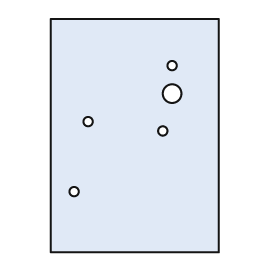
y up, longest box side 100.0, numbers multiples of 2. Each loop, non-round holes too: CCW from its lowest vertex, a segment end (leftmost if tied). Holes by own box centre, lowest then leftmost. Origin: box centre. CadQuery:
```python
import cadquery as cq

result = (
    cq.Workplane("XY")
    .moveTo(-36.0, -50.0)
    .lineTo(36.0, -50.0)
    .lineTo(36.0, 50.0)
    .lineTo(-36.0, 50.0)
    .close()
    .moveTo(-26.0, -24.0)
    .circle(2.0)
    .moveTo(12.0, 2.0)
    .circle(2.0)
    .moveTo(-20.0, 6.0)
    .circle(2.0)
    .moveTo(16.0, 18.0)
    .circle(4.0)
    .moveTo(16.0, 30.0)
    .circle(2.0)
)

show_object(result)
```